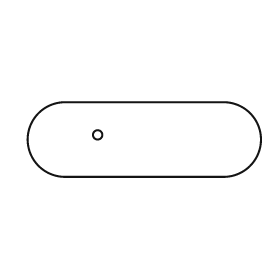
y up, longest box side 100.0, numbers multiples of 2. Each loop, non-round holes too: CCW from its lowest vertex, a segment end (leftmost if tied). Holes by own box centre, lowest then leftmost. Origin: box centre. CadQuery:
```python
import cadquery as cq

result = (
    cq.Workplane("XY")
    .moveTo(-34.0, -16.0)
    .lineTo(34.0, -16.0)
    .threePointArc((50.0, 0.0), (34.0, 16.0))
    .lineTo(-34.0, 16.0)
    .threePointArc((-50.0, 0.0), (-34.0, -16.0))
    .close()
    .moveTo(-20.0, 2.0)
    .circle(2.0)
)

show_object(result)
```